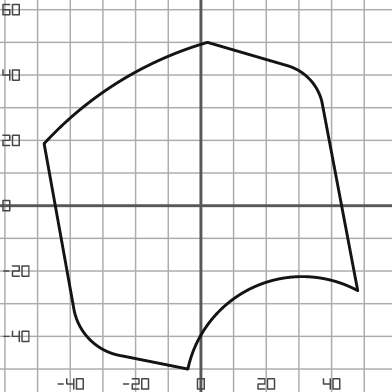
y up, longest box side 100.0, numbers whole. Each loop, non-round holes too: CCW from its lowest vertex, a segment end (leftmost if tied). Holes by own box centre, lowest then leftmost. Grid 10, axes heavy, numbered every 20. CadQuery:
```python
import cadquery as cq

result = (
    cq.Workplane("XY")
    .moveTo(-4.0, -50.0)
    .threePointArc((16.0, -25.0), (48.0, -26.0))
    .lineTo(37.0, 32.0)
    .threePointArc((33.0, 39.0), (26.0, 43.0))
    .lineTo(2.0, 50.0)
    .threePointArc((-25.0, 38.0), (-48.0, 19.0))
    .lineTo(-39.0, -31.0)
    .threePointArc((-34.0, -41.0), (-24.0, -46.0))
    .close()
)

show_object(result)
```